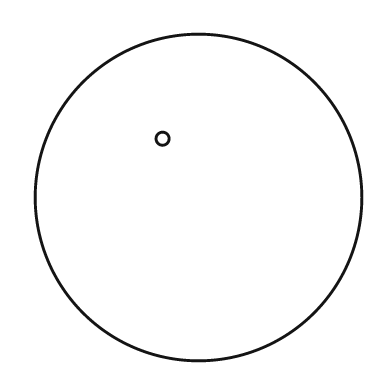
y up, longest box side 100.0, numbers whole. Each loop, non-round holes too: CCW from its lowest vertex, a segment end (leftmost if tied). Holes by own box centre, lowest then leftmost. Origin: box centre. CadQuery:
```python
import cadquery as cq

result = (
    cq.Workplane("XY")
    .moveTo(0.0, 0.0)
    .circle(50.0)
    .moveTo(-11.0, 18.0)
    .circle(2.0)
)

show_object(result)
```